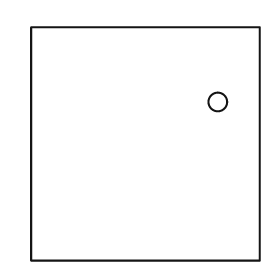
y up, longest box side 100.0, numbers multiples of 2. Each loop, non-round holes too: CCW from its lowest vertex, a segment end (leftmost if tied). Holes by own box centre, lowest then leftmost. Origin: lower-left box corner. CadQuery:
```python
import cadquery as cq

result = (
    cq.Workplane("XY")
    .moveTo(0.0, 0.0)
    .lineTo(98.0, 0.0)
    .lineTo(98.0, 100.0)
    .lineTo(0.0, 100.0)
    .close()
    .moveTo(80.0, 68.0)
    .circle(4.0)
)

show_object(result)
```